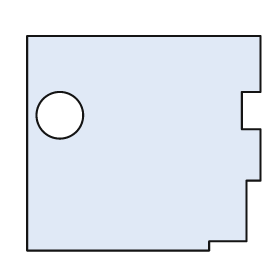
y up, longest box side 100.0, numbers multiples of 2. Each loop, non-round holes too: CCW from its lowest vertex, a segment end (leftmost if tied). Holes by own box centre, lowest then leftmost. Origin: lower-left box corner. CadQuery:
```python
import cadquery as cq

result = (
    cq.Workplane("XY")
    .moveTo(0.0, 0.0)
    .lineTo(78.0, 0.0)
    .lineTo(78.0, 4.0)
    .lineTo(94.0, 4.0)
    .lineTo(94.0, 30.0)
    .lineTo(100.0, 30.0)
    .lineTo(100.0, 52.0)
    .lineTo(92.0, 52.0)
    .lineTo(92.0, 68.0)
    .lineTo(100.0, 68.0)
    .lineTo(100.0, 92.0)
    .lineTo(0.0, 92.0)
    .close()
    .moveTo(14.0, 58.0)
    .circle(10.0)
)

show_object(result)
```